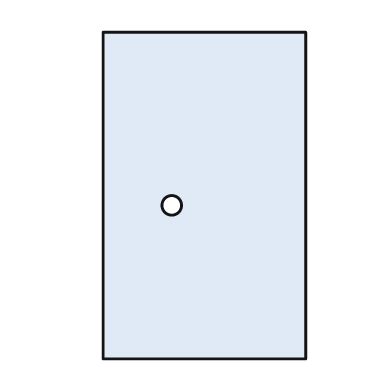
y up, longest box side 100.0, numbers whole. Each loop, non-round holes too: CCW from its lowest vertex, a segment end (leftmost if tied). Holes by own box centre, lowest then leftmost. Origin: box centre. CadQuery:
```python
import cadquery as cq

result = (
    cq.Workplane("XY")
    .moveTo(-31.0, -50.0)
    .lineTo(31.0, -50.0)
    .lineTo(31.0, 50.0)
    .lineTo(-31.0, 50.0)
    .close()
    .moveTo(-10.0, -3.0)
    .circle(3.0)
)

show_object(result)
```